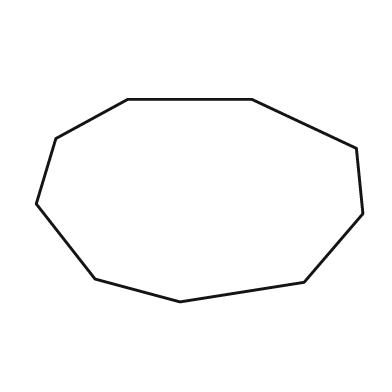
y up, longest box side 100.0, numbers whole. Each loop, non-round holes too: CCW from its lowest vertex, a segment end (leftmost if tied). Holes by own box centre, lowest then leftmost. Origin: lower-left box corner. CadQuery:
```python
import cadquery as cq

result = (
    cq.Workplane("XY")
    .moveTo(44.0, 0.0)
    .lineTo(82.0, 6.0)
    .lineTo(100.0, 27.0)
    .lineTo(98.0, 47.0)
    .lineTo(66.0, 62.0)
    .lineTo(28.0, 62.0)
    .lineTo(6.0, 50.0)
    .lineTo(0.0, 30.0)
    .lineTo(18.0, 7.0)
    .close()
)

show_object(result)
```